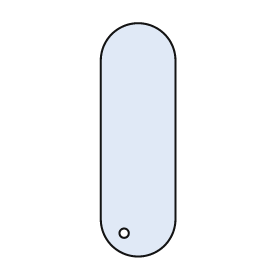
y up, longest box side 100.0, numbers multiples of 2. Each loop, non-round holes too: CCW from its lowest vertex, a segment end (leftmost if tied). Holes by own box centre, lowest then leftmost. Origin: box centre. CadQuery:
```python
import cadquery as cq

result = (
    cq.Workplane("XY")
    .moveTo(-16.0, -34.0)
    .threePointArc((0.0, -50.0), (16.0, -34.0))
    .lineTo(16.0, 34.0)
    .threePointArc((0.0, 50.0), (-16.0, 34.0))
    .close()
    .moveTo(-6.0, -40.0)
    .circle(2.0)
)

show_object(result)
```